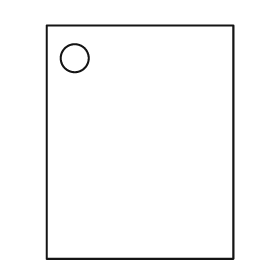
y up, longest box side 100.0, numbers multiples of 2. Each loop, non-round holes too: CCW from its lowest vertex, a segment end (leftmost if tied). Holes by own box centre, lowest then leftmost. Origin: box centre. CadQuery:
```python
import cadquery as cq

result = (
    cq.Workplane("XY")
    .moveTo(-40.0, -50.0)
    .lineTo(40.0, -50.0)
    .lineTo(40.0, 50.0)
    .lineTo(-40.0, 50.0)
    .close()
    .moveTo(-28.0, 36.0)
    .circle(6.0)
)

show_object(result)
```